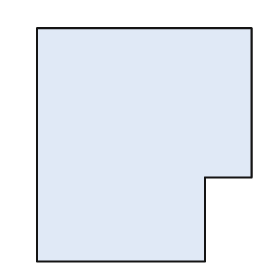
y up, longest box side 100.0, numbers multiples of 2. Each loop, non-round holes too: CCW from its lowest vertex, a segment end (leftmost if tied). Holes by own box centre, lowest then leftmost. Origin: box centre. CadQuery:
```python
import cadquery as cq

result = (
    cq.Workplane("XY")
    .moveTo(-46.0, -50.0)
    .lineTo(26.0, -50.0)
    .lineTo(26.0, -14.0)
    .lineTo(46.0, -14.0)
    .lineTo(46.0, 50.0)
    .lineTo(-46.0, 50.0)
    .close()
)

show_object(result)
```